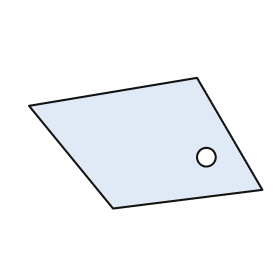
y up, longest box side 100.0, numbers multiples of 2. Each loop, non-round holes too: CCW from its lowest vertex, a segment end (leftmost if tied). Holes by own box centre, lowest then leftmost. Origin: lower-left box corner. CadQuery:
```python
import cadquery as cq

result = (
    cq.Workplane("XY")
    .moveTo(36.0, 0.0)
    .lineTo(100.0, 8.0)
    .lineTo(72.0, 56.0)
    .lineTo(0.0, 44.0)
    .close()
    .moveTo(76.0, 22.0)
    .circle(4.0)
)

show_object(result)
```